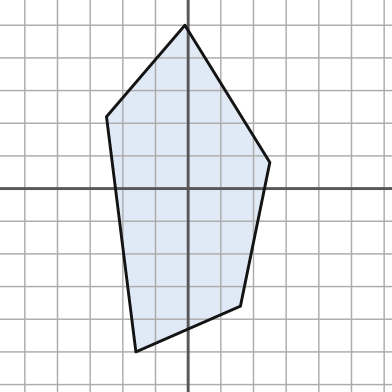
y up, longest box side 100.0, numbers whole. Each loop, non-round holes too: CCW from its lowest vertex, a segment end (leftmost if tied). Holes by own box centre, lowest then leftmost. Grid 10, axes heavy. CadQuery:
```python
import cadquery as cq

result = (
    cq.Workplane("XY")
    .moveTo(-16.0, -50.0)
    .lineTo(16.0, -36.0)
    .lineTo(25.0, 8.0)
    .lineTo(-1.0, 50.0)
    .lineTo(-25.0, 22.0)
    .close()
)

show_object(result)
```